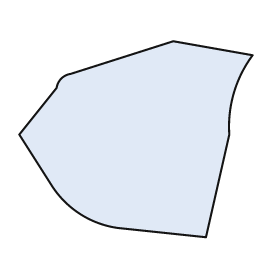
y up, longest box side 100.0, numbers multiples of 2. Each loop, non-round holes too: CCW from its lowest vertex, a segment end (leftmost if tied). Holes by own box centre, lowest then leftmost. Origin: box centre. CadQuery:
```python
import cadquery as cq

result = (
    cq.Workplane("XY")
    .moveTo(30.0, -42.0)
    .lineTo(40.0, 2.0)
    .threePointArc((42.0, 20.0), (50.0, 36.0))
    .lineTo(16.0, 42.0)
    .lineTo(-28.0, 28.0)
    .threePointArc((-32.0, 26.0), (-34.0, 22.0))
    .lineTo(-50.0, 2.0)
    .lineTo(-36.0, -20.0)
    .threePointArc((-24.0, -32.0), (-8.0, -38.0))
    .close()
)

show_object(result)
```